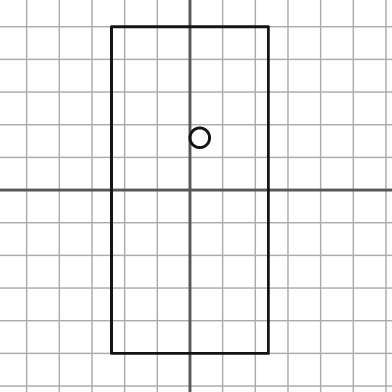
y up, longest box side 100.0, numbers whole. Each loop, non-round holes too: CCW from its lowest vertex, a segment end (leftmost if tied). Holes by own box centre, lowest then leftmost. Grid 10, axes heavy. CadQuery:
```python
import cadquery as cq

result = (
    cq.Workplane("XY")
    .moveTo(-24.0, -50.0)
    .lineTo(24.0, -50.0)
    .lineTo(24.0, 50.0)
    .lineTo(-24.0, 50.0)
    .close()
    .moveTo(3.0, 16.0)
    .circle(3.0)
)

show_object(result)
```